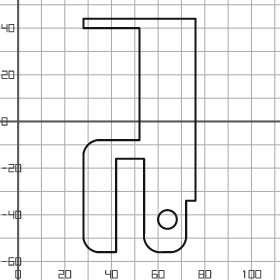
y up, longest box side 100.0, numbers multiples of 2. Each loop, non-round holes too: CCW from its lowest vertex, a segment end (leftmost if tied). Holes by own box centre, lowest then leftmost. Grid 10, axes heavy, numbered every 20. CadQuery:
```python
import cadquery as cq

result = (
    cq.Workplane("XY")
    .moveTo(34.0, -56.0)
    .lineTo(42.0, -56.0)
    .lineTo(42.0, -16.0)
    .lineTo(54.0, -16.0)
    .lineTo(54.0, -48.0)
    .threePointArc((56.0, -54.0), (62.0, -56.0))
    .lineTo(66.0, -56.0)
    .threePointArc((70.0, -54.0), (72.0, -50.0))
    .lineTo(72.0, -34.0)
    .lineTo(76.0, -34.0)
    .lineTo(76.0, 44.0)
    .lineTo(28.0, 44.0)
    .lineTo(28.0, 40.0)
    .lineTo(52.0, 40.0)
    .lineTo(52.0, -8.0)
    .lineTo(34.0, -8.0)
    .threePointArc((30.0, -10.0), (28.0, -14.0))
    .lineTo(28.0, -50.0)
    .threePointArc((30.0, -54.0), (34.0, -56.0))
    .close()
    .moveTo(64.0, -42.0)
    .circle(4.0)
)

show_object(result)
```